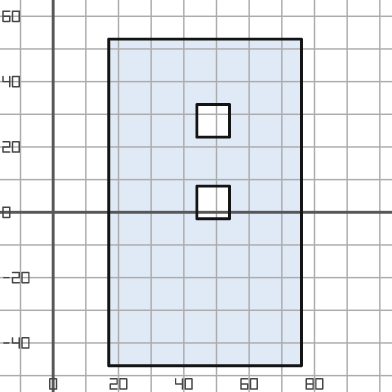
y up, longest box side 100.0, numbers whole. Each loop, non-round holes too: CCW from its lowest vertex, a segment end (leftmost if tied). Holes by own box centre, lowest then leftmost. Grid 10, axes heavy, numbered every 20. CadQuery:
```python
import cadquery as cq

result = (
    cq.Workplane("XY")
    .moveTo(17.0, -47.0)
    .lineTo(76.0, -47.0)
    .lineTo(76.0, 53.0)
    .lineTo(17.0, 53.0)
    .close()
    .moveTo(44.0, -2.0)
    .lineTo(54.0, -2.0)
    .lineTo(54.0, 8.0)
    .lineTo(44.0, 8.0)
    .close()
    .moveTo(44.0, 23.0)
    .lineTo(54.0, 23.0)
    .lineTo(54.0, 33.0)
    .lineTo(44.0, 33.0)
    .close()
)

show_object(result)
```